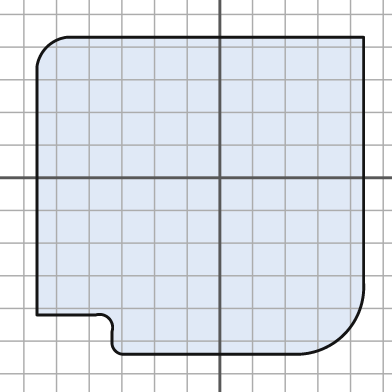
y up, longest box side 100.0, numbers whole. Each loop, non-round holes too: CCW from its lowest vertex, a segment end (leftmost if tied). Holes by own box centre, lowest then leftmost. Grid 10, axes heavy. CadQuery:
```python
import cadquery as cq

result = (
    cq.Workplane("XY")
    .moveTo(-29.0, -54.0)
    .lineTo(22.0, -54.0)
    .threePointArc((38.0, -48.0), (44.0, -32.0))
    .lineTo(44.0, 43.0)
    .lineTo(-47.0, 43.0)
    .threePointArc((-53.0, 40.0), (-56.0, 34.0))
    .lineTo(-56.0, -42.0)
    .lineTo(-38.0, -42.0)
    .threePointArc((-34.0, -43.0), (-33.0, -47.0))
    .lineTo(-33.0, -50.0)
    .threePointArc((-32.0, -53.0), (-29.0, -54.0))
    .close()
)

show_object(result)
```